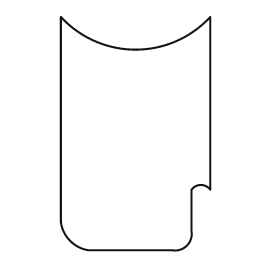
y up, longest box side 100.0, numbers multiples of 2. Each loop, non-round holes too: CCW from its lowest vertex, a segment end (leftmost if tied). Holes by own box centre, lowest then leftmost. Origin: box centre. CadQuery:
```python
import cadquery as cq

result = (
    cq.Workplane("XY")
    .moveTo(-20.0, -50.0)
    .lineTo(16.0, -50.0)
    .threePointArc((22.0, -48.0), (24.0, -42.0))
    .lineTo(24.0, -24.0)
    .threePointArc((28.0, -22.0), (32.0, -24.0))
    .lineTo(32.0, 50.0)
    .threePointArc((0.0, 36.0), (-32.0, 50.0))
    .lineTo(-32.0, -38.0)
    .threePointArc((-28.0, -46.0), (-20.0, -50.0))
    .close()
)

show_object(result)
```